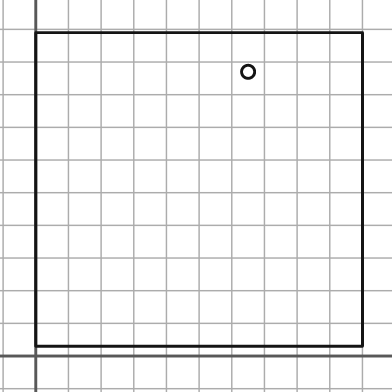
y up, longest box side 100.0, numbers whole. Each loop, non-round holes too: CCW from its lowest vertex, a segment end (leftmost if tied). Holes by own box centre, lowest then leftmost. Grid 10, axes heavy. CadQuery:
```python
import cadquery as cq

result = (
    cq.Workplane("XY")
    .moveTo(0.0, 3.0)
    .lineTo(100.0, 3.0)
    .lineTo(100.0, 99.0)
    .lineTo(0.0, 99.0)
    .close()
    .moveTo(65.0, 87.0)
    .circle(2.0)
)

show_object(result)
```